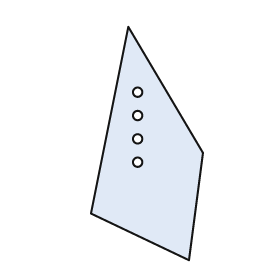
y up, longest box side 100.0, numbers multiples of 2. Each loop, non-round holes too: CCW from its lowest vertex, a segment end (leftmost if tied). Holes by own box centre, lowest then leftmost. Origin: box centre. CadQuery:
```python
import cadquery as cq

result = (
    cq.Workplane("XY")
    .moveTo(18.0, -50.0)
    .lineTo(24.0, -4.0)
    .lineTo(-8.0, 50.0)
    .lineTo(-24.0, -30.0)
    .close()
    .moveTo(-4.0, -8.0)
    .circle(2.0)
    .moveTo(-4.0, 2.0)
    .circle(2.0)
    .moveTo(-4.0, 12.0)
    .circle(2.0)
    .moveTo(-4.0, 22.0)
    .circle(2.0)
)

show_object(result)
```